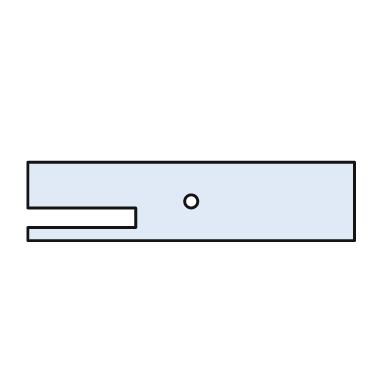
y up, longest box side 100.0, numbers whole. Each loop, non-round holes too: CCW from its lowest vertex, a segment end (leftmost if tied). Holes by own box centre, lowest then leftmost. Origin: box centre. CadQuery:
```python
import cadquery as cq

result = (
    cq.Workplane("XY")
    .moveTo(-50.0, -12.0)
    .lineTo(50.0, -12.0)
    .lineTo(50.0, 12.0)
    .lineTo(-50.0, 12.0)
    .lineTo(-50.0, -2.0)
    .lineTo(-17.0, -2.0)
    .lineTo(-17.0, -8.0)
    .lineTo(-50.0, -8.0)
    .close()
    .moveTo(0.0, 0.0)
    .circle(2.0)
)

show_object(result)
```